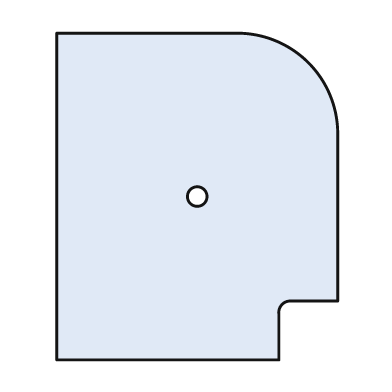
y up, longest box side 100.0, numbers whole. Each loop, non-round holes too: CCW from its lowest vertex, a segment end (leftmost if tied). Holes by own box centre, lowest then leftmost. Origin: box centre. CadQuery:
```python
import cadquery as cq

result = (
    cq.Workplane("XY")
    .moveTo(-43.0, -50.0)
    .lineTo(25.0, -50.0)
    .lineTo(25.0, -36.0)
    .threePointArc((26.0, -33.0), (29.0, -32.0))
    .lineTo(43.0, -32.0)
    .lineTo(43.0, 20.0)
    .threePointArc((34.0, 41.0), (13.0, 50.0))
    .lineTo(-43.0, 50.0)
    .close()
    .moveTo(0.0, 0.0)
    .circle(3.0)
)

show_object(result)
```